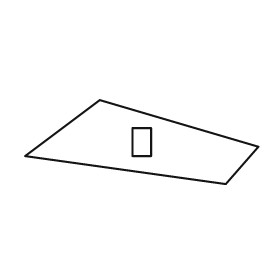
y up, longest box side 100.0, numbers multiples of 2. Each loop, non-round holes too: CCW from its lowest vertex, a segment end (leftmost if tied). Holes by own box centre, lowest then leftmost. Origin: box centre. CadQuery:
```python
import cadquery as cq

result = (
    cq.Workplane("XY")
    .moveTo(36.0, -18.0)
    .lineTo(50.0, -2.0)
    .lineTo(-18.0, 18.0)
    .lineTo(-50.0, -6.0)
    .close()
    .moveTo(-4.0, -6.0)
    .lineTo(4.0, -6.0)
    .lineTo(4.0, 6.0)
    .lineTo(-4.0, 6.0)
    .close()
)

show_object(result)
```